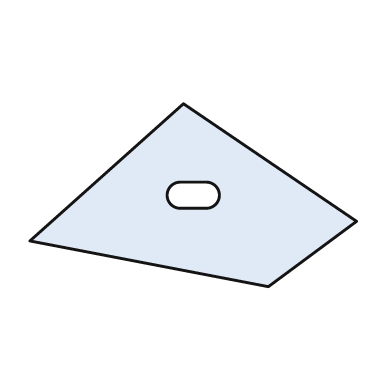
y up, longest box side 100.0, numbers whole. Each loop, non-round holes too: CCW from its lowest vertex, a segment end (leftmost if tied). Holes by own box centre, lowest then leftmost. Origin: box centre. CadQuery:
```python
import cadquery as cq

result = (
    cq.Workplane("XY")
    .moveTo(23.0, -28.0)
    .lineTo(50.0, -8.0)
    .lineTo(-3.0, 28.0)
    .lineTo(-50.0, -14.0)
    .close()
    .moveTo(-4.0, -4.0)
    .lineTo(4.0, -4.0)
    .threePointArc((8.0, 0.0), (4.0, 4.0))
    .lineTo(-4.0, 4.0)
    .threePointArc((-8.0, 0.0), (-4.0, -4.0))
    .close()
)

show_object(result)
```